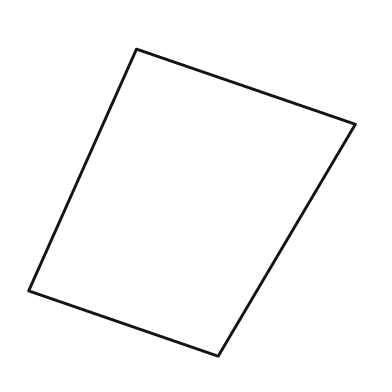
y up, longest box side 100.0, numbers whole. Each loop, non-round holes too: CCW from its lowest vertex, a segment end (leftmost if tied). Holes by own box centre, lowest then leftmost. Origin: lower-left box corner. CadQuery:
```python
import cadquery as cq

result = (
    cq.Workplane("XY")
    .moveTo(58.0, 0.0)
    .lineTo(100.0, 71.0)
    .lineTo(33.0, 94.0)
    .lineTo(0.0, 20.0)
    .close()
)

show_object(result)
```